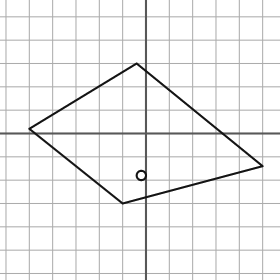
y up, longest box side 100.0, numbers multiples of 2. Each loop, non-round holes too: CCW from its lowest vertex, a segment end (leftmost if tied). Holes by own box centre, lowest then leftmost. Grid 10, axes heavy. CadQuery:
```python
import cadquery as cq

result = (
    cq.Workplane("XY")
    .moveTo(-10.0, -30.0)
    .lineTo(50.0, -14.0)
    .lineTo(-4.0, 30.0)
    .lineTo(-50.0, 2.0)
    .close()
    .moveTo(-2.0, -18.0)
    .circle(2.0)
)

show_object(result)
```